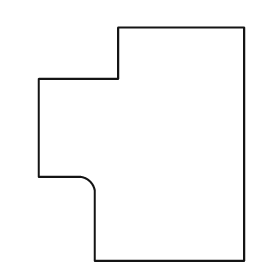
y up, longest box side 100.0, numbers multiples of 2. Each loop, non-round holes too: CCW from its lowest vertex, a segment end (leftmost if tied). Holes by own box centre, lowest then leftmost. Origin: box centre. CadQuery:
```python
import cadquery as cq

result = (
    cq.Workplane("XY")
    .moveTo(-20.0, -50.0)
    .lineTo(44.0, -50.0)
    .lineTo(44.0, 50.0)
    .lineTo(-10.0, 50.0)
    .lineTo(-10.0, 28.0)
    .lineTo(-44.0, 28.0)
    .lineTo(-44.0, -14.0)
    .lineTo(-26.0, -14.0)
    .threePointArc((-22.0, -16.0), (-20.0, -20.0))
    .close()
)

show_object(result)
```